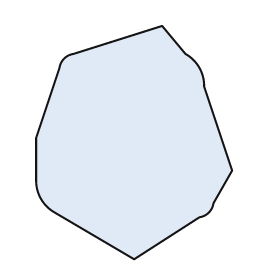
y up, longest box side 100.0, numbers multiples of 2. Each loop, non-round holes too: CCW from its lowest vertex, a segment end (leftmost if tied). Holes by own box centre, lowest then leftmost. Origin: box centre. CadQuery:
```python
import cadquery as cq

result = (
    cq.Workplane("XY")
    .moveTo(0.0, -50.0)
    .lineTo(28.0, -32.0)
    .threePointArc((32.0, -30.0), (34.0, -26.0))
    .lineTo(42.0, -12.0)
    .lineTo(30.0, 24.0)
    .threePointArc((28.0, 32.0), (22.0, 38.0))
    .lineTo(12.0, 50.0)
    .lineTo(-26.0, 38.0)
    .threePointArc((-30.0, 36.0), (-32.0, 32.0))
    .lineTo(-42.0, 2.0)
    .lineTo(-42.0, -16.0)
    .threePointArc((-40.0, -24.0), (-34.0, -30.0))
    .close()
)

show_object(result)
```